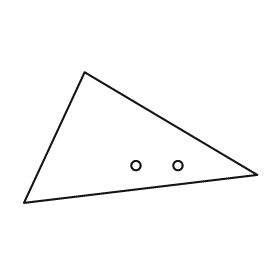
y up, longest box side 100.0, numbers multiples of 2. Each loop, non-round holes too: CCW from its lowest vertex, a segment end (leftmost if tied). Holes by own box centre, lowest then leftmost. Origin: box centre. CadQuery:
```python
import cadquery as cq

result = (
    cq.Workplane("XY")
    .moveTo(-50.0, -28.0)
    .lineTo(50.0, -16.0)
    .lineTo(-24.0, 28.0)
    .close()
    .moveTo(-2.0, -12.0)
    .circle(2.0)
    .moveTo(16.0, -12.0)
    .circle(2.0)
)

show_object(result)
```